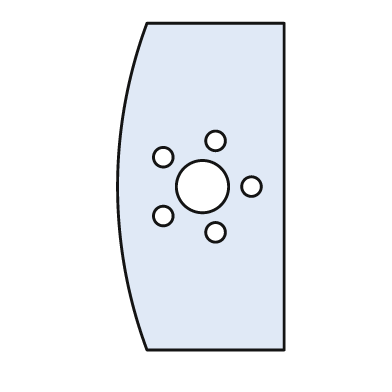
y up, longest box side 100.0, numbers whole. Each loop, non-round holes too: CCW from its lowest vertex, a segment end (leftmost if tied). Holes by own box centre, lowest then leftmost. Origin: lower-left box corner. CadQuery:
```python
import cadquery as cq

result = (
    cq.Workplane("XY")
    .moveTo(9.0, 0.0)
    .lineTo(51.0, 0.0)
    .lineTo(51.0, 100.0)
    .lineTo(9.0, 100.0)
    .threePointArc((0.0, 50.0), (9.0, 0.0))
    .close()
    .moveTo(30.0, 36.0)
    .circle(3.0)
    .moveTo(14.0, 41.0)
    .circle(3.0)
    .moveTo(26.0, 50.0)
    .circle(8.0)
    .moveTo(41.0, 50.0)
    .circle(3.0)
    .moveTo(14.0, 59.0)
    .circle(3.0)
    .moveTo(30.0, 64.0)
    .circle(3.0)
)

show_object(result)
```